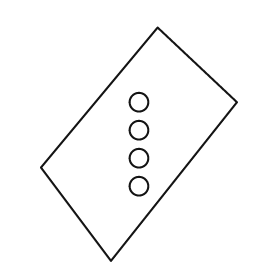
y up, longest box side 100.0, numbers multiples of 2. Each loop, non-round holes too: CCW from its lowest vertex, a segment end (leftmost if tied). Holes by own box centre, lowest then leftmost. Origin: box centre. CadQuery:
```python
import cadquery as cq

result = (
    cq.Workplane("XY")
    .moveTo(-12.0, -50.0)
    .lineTo(42.0, 18.0)
    .lineTo(8.0, 50.0)
    .lineTo(-42.0, -10.0)
    .close()
    .moveTo(0.0, -18.0)
    .circle(4.0)
    .moveTo(0.0, -6.0)
    .circle(4.0)
    .moveTo(0.0, 6.0)
    .circle(4.0)
    .moveTo(0.0, 18.0)
    .circle(4.0)
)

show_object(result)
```